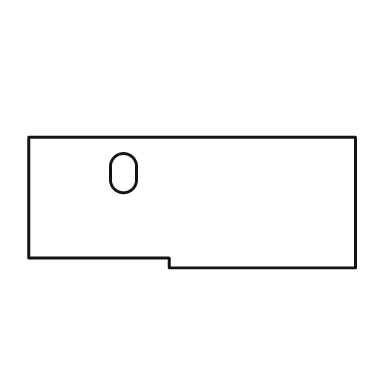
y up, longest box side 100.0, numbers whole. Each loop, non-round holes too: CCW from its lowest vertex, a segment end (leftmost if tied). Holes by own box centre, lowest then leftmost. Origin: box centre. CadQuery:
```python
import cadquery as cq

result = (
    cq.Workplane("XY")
    .moveTo(-7.0, -20.0)
    .lineTo(50.0, -20.0)
    .lineTo(50.0, 20.0)
    .lineTo(-50.0, 20.0)
    .lineTo(-50.0, -17.0)
    .lineTo(-7.0, -17.0)
    .close()
    .moveTo(-25.0, 7.0)
    .threePointArc((-21.0, 3.0), (-17.0, 7.0))
    .lineTo(-17.0, 11.0)
    .threePointArc((-21.0, 15.0), (-25.0, 11.0))
    .close()
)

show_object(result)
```